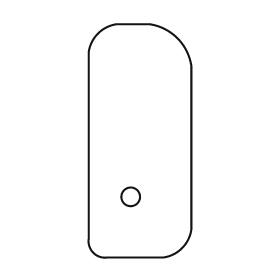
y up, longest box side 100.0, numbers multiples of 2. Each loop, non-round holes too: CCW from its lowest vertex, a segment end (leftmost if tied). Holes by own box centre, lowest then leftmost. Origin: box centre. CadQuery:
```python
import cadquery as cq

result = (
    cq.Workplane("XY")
    .moveTo(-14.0, -50.0)
    .lineTo(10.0, -50.0)
    .threePointArc((18.0, -46.0), (22.0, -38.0))
    .lineTo(22.0, 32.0)
    .threePointArc((16.0, 44.0), (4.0, 50.0))
    .lineTo(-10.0, 50.0)
    .threePointArc((-18.0, 46.0), (-22.0, 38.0))
    .lineTo(-22.0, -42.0)
    .threePointArc((-20.0, -48.0), (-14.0, -50.0))
    .close()
    .moveTo(-4.0, -24.0)
    .circle(4.0)
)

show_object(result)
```